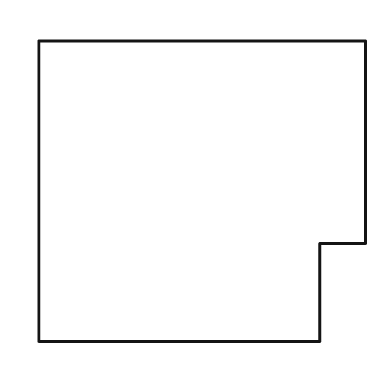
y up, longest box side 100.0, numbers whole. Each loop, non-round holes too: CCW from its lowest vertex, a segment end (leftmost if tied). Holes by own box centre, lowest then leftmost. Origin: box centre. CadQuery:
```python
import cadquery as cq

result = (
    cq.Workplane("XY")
    .moveTo(-50.0, -46.0)
    .lineTo(36.0, -46.0)
    .lineTo(36.0, -16.0)
    .lineTo(50.0, -16.0)
    .lineTo(50.0, 46.0)
    .lineTo(-50.0, 46.0)
    .close()
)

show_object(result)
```